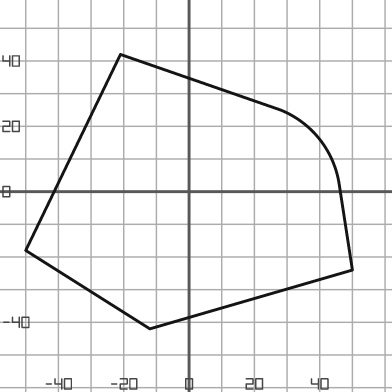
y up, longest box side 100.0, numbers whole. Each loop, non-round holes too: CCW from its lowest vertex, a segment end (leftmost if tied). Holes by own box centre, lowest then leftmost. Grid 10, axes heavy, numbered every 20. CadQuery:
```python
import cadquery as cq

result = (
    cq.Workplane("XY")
    .moveTo(-12.0, -42.0)
    .lineTo(50.0, -24.0)
    .lineTo(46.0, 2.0)
    .threePointArc((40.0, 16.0), (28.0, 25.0))
    .lineTo(-21.0, 42.0)
    .lineTo(-50.0, -18.0)
    .close()
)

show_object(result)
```